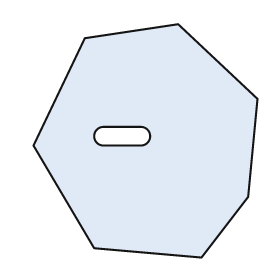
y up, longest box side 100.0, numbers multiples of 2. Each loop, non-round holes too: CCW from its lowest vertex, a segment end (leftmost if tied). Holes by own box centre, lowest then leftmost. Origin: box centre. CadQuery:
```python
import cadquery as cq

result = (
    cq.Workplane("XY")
    .moveTo(24.0, -50.0)
    .lineTo(44.0, -24.0)
    .lineTo(48.0, 18.0)
    .lineTo(14.0, 50.0)
    .lineTo(-26.0, 44.0)
    .lineTo(-48.0, -2.0)
    .lineTo(-22.0, -46.0)
    .close()
    .moveTo(-18.0, -2.0)
    .lineTo(-2.0, -2.0)
    .threePointArc((2.0, 2.0), (-2.0, 6.0))
    .lineTo(-18.0, 6.0)
    .threePointArc((-22.0, 2.0), (-18.0, -2.0))
    .close()
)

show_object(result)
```